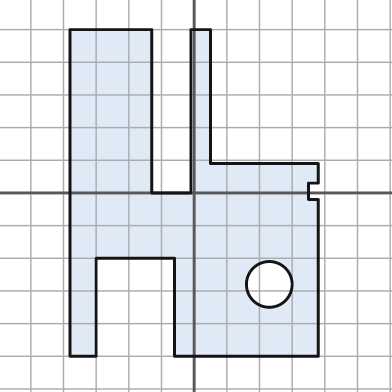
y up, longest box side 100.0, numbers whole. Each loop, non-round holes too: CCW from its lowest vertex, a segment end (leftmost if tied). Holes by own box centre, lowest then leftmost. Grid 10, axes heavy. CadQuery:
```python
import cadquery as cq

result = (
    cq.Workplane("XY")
    .moveTo(-38.0, -50.0)
    .lineTo(-30.0, -50.0)
    .lineTo(-30.0, -20.0)
    .lineTo(-6.0, -20.0)
    .lineTo(-6.0, -50.0)
    .lineTo(38.0, -50.0)
    .lineTo(38.0, -2.0)
    .lineTo(35.0, -2.0)
    .lineTo(35.0, 3.0)
    .lineTo(38.0, 3.0)
    .lineTo(38.0, 9.0)
    .lineTo(5.0, 9.0)
    .lineTo(5.0, 50.0)
    .lineTo(-1.0, 50.0)
    .lineTo(-1.0, 0.0)
    .lineTo(-13.0, 0.0)
    .lineTo(-13.0, 50.0)
    .lineTo(-38.0, 50.0)
    .close()
    .moveTo(23.0, -28.0)
    .circle(7.0)
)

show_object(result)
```